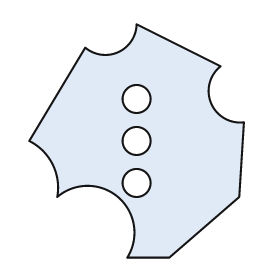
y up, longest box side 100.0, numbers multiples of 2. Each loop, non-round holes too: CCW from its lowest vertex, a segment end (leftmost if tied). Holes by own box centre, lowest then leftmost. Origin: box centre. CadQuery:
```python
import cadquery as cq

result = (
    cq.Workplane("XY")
    .moveTo(-4.0, -50.0)
    .lineTo(14.0, -50.0)
    .lineTo(44.0, -24.0)
    .lineTo(46.0, 8.0)
    .threePointArc((32.0, 16.0), (36.0, 32.0))
    .lineTo(0.0, 50.0)
    .threePointArc((-8.0, 38.0), (-22.0, 40.0))
    .lineTo(-46.0, 0.0)
    .threePointArc((-36.0, -10.0), (-34.0, -24.0))
    .threePointArc((-8.0, -24.0), (-4.0, -50.0))
    .close()
    .moveTo(0.0, -18.0)
    .circle(6.0)
    .moveTo(0.0, 0.0)
    .circle(6.0)
    .moveTo(0.0, 18.0)
    .circle(6.0)
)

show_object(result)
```